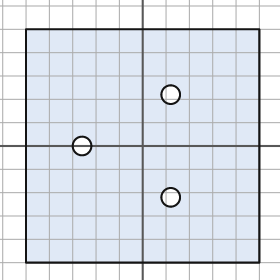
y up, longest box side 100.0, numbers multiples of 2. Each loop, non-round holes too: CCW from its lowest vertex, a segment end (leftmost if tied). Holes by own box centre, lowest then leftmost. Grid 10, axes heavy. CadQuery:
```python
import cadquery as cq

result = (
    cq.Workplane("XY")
    .moveTo(-50.0, -50.0)
    .lineTo(50.0, -50.0)
    .lineTo(50.0, 50.0)
    .lineTo(-50.0, 50.0)
    .close()
    .moveTo(12.0, -22.0)
    .circle(4.0)
    .moveTo(-26.0, 0.0)
    .circle(4.0)
    .moveTo(12.0, 22.0)
    .circle(4.0)
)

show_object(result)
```